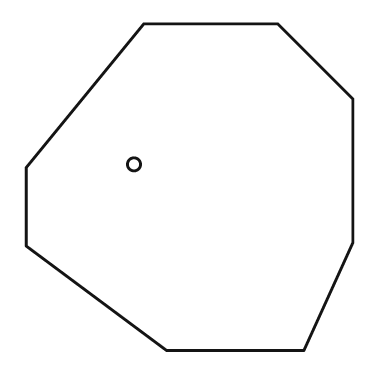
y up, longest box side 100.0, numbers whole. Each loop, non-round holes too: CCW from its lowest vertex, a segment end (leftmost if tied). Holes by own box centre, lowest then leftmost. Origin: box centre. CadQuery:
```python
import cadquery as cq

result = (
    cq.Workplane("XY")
    .moveTo(-7.0, -50.0)
    .lineTo(35.0, -50.0)
    .lineTo(50.0, -17.0)
    .lineTo(50.0, 27.0)
    .lineTo(27.0, 50.0)
    .lineTo(-14.0, 50.0)
    .lineTo(-50.0, 6.0)
    .lineTo(-50.0, -18.0)
    .close()
    .moveTo(-17.0, 7.0)
    .circle(2.0)
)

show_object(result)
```